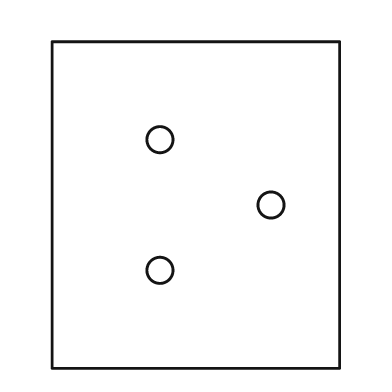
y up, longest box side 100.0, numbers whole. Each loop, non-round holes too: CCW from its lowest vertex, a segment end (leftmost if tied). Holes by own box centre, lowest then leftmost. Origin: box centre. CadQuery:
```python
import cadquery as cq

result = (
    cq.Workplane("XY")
    .moveTo(-44.0, -50.0)
    .lineTo(44.0, -50.0)
    .lineTo(44.0, 50.0)
    .lineTo(-44.0, 50.0)
    .close()
    .moveTo(-11.0, -20.0)
    .circle(4.0)
    .moveTo(23.0, 0.0)
    .circle(4.0)
    .moveTo(-11.0, 20.0)
    .circle(4.0)
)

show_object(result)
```